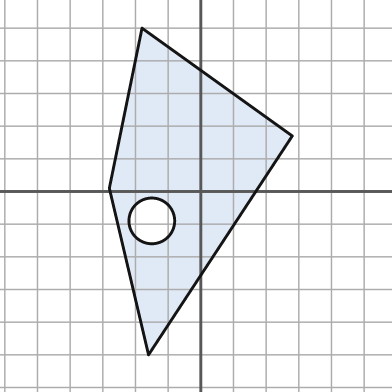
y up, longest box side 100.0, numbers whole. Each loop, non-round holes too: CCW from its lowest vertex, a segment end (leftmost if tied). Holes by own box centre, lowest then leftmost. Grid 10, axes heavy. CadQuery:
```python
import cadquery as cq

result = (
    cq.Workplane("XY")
    .moveTo(-16.0, -50.0)
    .lineTo(28.0, 17.0)
    .lineTo(-18.0, 50.0)
    .lineTo(-28.0, 1.0)
    .close()
    .moveTo(-15.0, -9.0)
    .circle(7.0)
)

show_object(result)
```